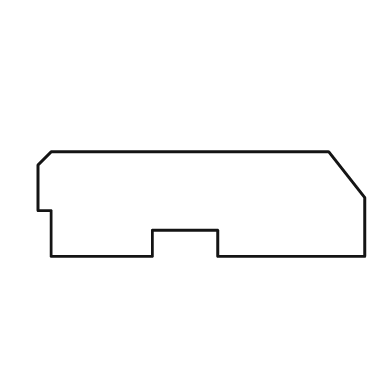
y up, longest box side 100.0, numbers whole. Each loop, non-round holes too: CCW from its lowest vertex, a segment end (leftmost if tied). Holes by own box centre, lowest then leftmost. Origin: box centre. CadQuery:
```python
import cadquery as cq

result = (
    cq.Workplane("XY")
    .moveTo(-46.0, -16.0)
    .lineTo(-15.0, -16.0)
    .lineTo(-15.0, -8.0)
    .lineTo(5.0, -8.0)
    .lineTo(5.0, -16.0)
    .lineTo(50.0, -16.0)
    .lineTo(50.0, 2.0)
    .lineTo(39.0, 16.0)
    .lineTo(-46.0, 16.0)
    .lineTo(-50.0, 12.0)
    .lineTo(-50.0, -2.0)
    .lineTo(-46.0, -2.0)
    .close()
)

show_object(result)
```